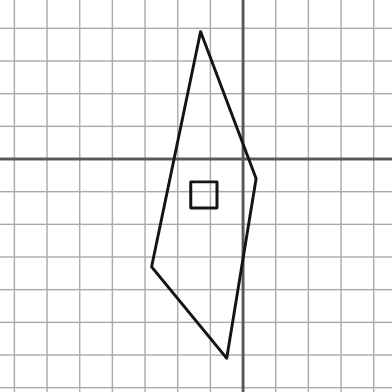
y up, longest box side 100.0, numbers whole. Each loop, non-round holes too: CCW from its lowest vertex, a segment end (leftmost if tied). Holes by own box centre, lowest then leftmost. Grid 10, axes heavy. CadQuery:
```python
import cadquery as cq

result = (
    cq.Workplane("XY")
    .moveTo(-5.0, -61.0)
    .lineTo(4.0, -6.0)
    .lineTo(-13.0, 39.0)
    .lineTo(-28.0, -33.0)
    .close()
    .moveTo(-16.0, -15.0)
    .lineTo(-8.0, -15.0)
    .lineTo(-8.0, -7.0)
    .lineTo(-16.0, -7.0)
    .close()
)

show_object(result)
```